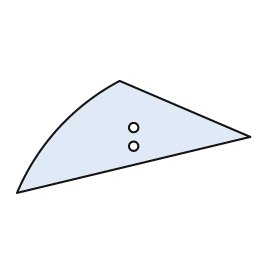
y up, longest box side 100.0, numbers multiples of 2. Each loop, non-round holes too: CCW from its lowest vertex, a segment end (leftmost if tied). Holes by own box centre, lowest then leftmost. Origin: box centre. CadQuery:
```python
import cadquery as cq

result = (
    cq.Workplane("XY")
    .moveTo(-50.0, -24.0)
    .lineTo(50.0, 0.0)
    .lineTo(-6.0, 24.0)
    .threePointArc((-32.0, 4.0), (-50.0, -24.0))
    .close()
    .moveTo(0.0, -4.0)
    .circle(2.0)
    .moveTo(0.0, 4.0)
    .circle(2.0)
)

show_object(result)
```